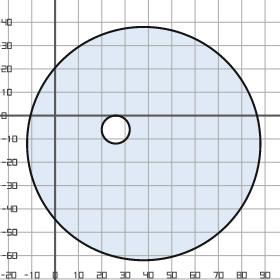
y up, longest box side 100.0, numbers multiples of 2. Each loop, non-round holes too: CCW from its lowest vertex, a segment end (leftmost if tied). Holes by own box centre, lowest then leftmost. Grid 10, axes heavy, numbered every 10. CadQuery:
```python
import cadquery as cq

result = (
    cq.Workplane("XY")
    .moveTo(38.0, -12.0)
    .circle(50.0)
    .moveTo(26.0, -6.0)
    .circle(6.0)
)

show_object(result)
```